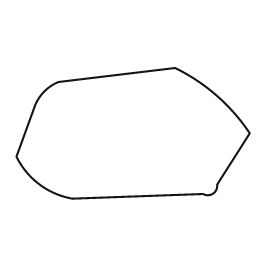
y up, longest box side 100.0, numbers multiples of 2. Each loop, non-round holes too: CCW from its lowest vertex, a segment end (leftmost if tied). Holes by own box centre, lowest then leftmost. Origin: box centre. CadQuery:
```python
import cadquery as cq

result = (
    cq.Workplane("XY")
    .moveTo(-26.0, -28.0)
    .lineTo(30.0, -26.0)
    .threePointArc((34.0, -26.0), (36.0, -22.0))
    .lineTo(50.0, 0.0)
    .threePointArc((36.0, 16.0), (18.0, 28.0))
    .lineTo(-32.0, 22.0)
    .threePointArc((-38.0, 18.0), (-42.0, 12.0))
    .lineTo(-50.0, -10.0)
    .threePointArc((-40.0, -22.0), (-26.0, -28.0))
    .close()
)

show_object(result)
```